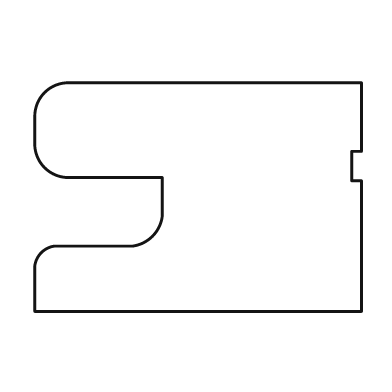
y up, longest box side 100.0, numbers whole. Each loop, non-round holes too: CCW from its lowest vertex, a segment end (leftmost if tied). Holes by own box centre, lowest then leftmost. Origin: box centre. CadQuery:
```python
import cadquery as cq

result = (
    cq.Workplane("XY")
    .moveTo(-50.0, -35.0)
    .lineTo(50.0, -35.0)
    .lineTo(50.0, 5.0)
    .lineTo(47.0, 5.0)
    .lineTo(47.0, 14.0)
    .lineTo(50.0, 14.0)
    .lineTo(50.0, 35.0)
    .lineTo(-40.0, 35.0)
    .threePointArc((-47.0, 32.0), (-50.0, 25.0))
    .lineTo(-50.0, 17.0)
    .threePointArc((-47.0, 9.0), (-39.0, 6.0))
    .lineTo(-11.0, 6.0)
    .lineTo(-11.0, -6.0)
    .threePointArc((-14.0, -12.0), (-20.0, -15.0))
    .lineTo(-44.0, -15.0)
    .threePointArc((-48.0, -17.0), (-50.0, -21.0))
    .close()
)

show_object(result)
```